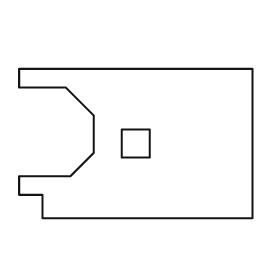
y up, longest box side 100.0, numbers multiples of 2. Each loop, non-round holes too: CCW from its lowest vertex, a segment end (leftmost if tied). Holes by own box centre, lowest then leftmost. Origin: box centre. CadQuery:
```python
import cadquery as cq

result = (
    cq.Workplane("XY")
    .moveTo(-40.0, -32.0)
    .lineTo(50.0, -32.0)
    .lineTo(50.0, 32.0)
    .lineTo(-50.0, 32.0)
    .lineTo(-50.0, 24.0)
    .lineTo(-30.0, 24.0)
    .lineTo(-18.0, 12.0)
    .lineTo(-18.0, -4.0)
    .lineTo(-28.0, -14.0)
    .lineTo(-50.0, -14.0)
    .lineTo(-50.0, -22.0)
    .lineTo(-40.0, -22.0)
    .close()
    .moveTo(-6.0, -6.0)
    .lineTo(6.0, -6.0)
    .lineTo(6.0, 6.0)
    .lineTo(-6.0, 6.0)
    .close()
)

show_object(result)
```